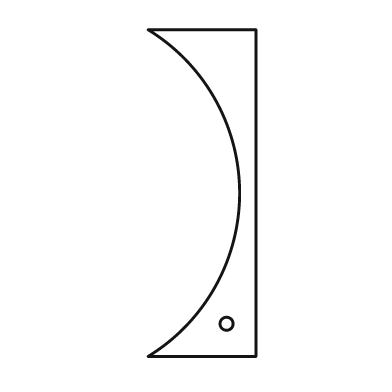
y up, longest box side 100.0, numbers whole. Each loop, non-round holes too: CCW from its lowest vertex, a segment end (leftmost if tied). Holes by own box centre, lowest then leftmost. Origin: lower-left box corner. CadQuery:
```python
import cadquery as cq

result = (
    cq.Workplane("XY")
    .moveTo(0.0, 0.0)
    .lineTo(33.0, 0.0)
    .lineTo(33.0, 100.0)
    .lineTo(0.0, 100.0)
    .threePointArc((28.0, 50.0), (0.0, 0.0))
    .close()
    .moveTo(24.0, 10.0)
    .circle(2.0)
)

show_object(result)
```